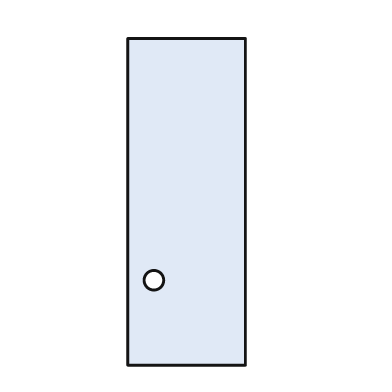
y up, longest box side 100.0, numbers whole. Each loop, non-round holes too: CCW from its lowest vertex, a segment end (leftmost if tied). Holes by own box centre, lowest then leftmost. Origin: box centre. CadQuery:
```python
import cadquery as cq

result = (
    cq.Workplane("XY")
    .moveTo(-18.0, -50.0)
    .lineTo(18.0, -50.0)
    .lineTo(18.0, 50.0)
    .lineTo(-18.0, 50.0)
    .close()
    .moveTo(-10.0, -24.0)
    .circle(3.0)
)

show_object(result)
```